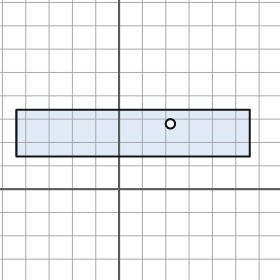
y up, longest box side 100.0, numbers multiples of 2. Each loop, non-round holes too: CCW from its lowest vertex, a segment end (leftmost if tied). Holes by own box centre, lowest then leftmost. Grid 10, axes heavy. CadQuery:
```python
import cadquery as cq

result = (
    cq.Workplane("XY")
    .moveTo(-44.0, 14.0)
    .lineTo(56.0, 14.0)
    .lineTo(56.0, 34.0)
    .lineTo(-44.0, 34.0)
    .close()
    .moveTo(22.0, 28.0)
    .circle(2.0)
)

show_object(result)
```